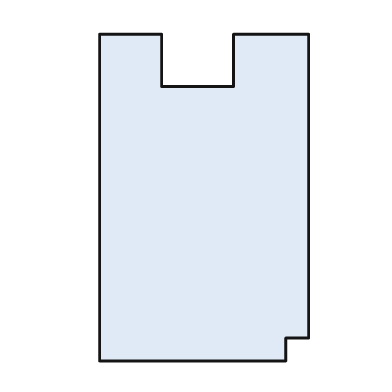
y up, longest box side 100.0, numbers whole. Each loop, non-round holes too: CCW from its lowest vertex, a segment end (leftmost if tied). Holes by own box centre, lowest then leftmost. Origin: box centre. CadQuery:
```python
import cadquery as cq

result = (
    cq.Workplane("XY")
    .moveTo(-32.0, -50.0)
    .lineTo(25.0, -50.0)
    .lineTo(25.0, -43.0)
    .lineTo(32.0, -43.0)
    .lineTo(32.0, 50.0)
    .lineTo(9.0, 50.0)
    .lineTo(9.0, 34.0)
    .lineTo(-13.0, 34.0)
    .lineTo(-13.0, 50.0)
    .lineTo(-32.0, 50.0)
    .close()
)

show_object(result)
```